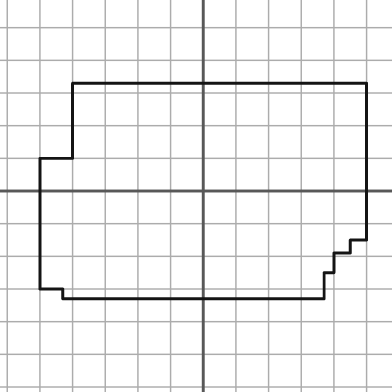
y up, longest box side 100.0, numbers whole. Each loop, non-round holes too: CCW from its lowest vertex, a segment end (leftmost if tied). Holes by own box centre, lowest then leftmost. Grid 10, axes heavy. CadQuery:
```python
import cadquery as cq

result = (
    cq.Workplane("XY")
    .moveTo(-43.0, -33.0)
    .lineTo(37.0, -33.0)
    .lineTo(37.0, -25.0)
    .lineTo(40.0, -25.0)
    .lineTo(40.0, -19.0)
    .lineTo(45.0, -19.0)
    .lineTo(45.0, -15.0)
    .lineTo(50.0, -15.0)
    .lineTo(50.0, 33.0)
    .lineTo(-40.0, 33.0)
    .lineTo(-40.0, 10.0)
    .lineTo(-50.0, 10.0)
    .lineTo(-50.0, -30.0)
    .lineTo(-43.0, -30.0)
    .close()
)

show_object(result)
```